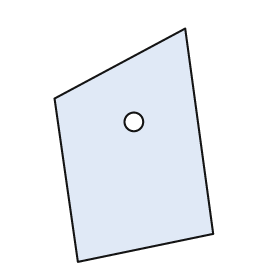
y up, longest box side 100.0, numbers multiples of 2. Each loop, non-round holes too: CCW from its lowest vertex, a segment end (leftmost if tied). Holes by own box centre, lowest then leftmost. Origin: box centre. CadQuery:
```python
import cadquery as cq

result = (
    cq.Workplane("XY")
    .moveTo(-24.0, -50.0)
    .lineTo(34.0, -38.0)
    .lineTo(22.0, 50.0)
    .lineTo(-34.0, 20.0)
    .close()
    .moveTo(0.0, 10.0)
    .circle(4.0)
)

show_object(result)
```